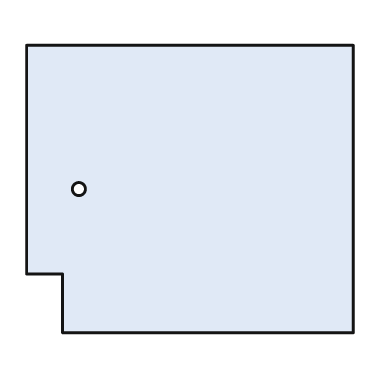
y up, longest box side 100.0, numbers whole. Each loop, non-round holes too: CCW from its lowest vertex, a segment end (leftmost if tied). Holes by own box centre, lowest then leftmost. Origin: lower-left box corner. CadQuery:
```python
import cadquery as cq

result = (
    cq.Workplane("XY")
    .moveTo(11.0, 0.0)
    .lineTo(100.0, 0.0)
    .lineTo(100.0, 88.0)
    .lineTo(0.0, 88.0)
    .lineTo(0.0, 18.0)
    .lineTo(11.0, 18.0)
    .close()
    .moveTo(16.0, 44.0)
    .circle(2.0)
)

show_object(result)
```